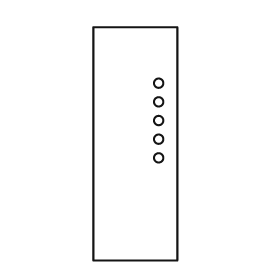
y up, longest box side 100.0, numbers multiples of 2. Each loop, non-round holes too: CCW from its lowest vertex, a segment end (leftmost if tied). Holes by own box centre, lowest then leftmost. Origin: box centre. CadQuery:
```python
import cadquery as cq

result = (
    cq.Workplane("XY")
    .moveTo(-18.0, -50.0)
    .lineTo(18.0, -50.0)
    .lineTo(18.0, 50.0)
    .lineTo(-18.0, 50.0)
    .close()
    .moveTo(10.0, -6.0)
    .circle(2.0)
    .moveTo(10.0, 2.0)
    .circle(2.0)
    .moveTo(10.0, 10.0)
    .circle(2.0)
    .moveTo(10.0, 18.0)
    .circle(2.0)
    .moveTo(10.0, 26.0)
    .circle(2.0)
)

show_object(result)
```